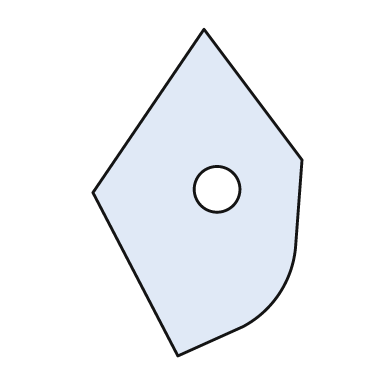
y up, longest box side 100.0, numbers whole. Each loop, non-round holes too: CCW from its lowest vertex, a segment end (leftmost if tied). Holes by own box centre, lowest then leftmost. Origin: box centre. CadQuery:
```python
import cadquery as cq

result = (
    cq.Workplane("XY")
    .moveTo(-6.0, -50.0)
    .lineTo(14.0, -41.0)
    .threePointArc((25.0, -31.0), (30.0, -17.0))
    .lineTo(32.0, 10.0)
    .lineTo(2.0, 50.0)
    .lineTo(-32.0, 0.0)
    .close()
    .moveTo(6.0, 1.0)
    .circle(7.0)
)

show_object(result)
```